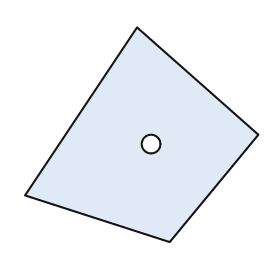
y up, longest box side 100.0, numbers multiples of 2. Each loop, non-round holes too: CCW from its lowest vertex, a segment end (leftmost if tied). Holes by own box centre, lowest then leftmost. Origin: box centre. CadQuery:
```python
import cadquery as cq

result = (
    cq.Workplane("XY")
    .moveTo(12.0, -46.0)
    .lineTo(50.0, 0.0)
    .lineTo(-2.0, 46.0)
    .lineTo(-50.0, -26.0)
    .close()
    .moveTo(4.0, -4.0)
    .circle(4.0)
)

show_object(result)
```